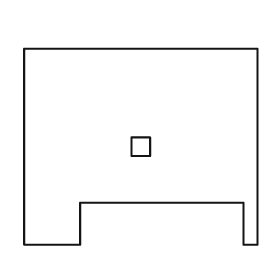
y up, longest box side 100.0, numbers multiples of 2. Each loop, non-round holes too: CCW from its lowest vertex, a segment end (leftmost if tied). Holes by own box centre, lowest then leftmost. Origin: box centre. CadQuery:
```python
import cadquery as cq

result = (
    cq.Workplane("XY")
    .moveTo(-50.0, -42.0)
    .lineTo(-26.0, -42.0)
    .lineTo(-26.0, -24.0)
    .lineTo(44.0, -24.0)
    .lineTo(44.0, -42.0)
    .lineTo(50.0, -42.0)
    .lineTo(50.0, 42.0)
    .lineTo(-50.0, 42.0)
    .close()
    .moveTo(-4.0, -4.0)
    .lineTo(4.0, -4.0)
    .lineTo(4.0, 4.0)
    .lineTo(-4.0, 4.0)
    .close()
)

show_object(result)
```